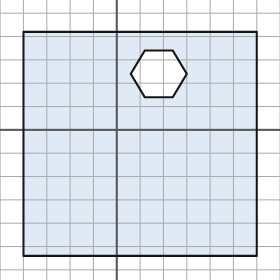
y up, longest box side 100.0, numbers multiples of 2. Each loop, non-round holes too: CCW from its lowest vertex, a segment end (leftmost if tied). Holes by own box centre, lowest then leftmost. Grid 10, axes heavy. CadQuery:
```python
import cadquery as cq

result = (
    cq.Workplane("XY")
    .moveTo(-40.0, -54.0)
    .lineTo(60.0, -54.0)
    .lineTo(60.0, 42.0)
    .lineTo(-40.0, 42.0)
    .close()
    .moveTo(12.0, 14.0)
    .lineTo(24.0, 14.0)
    .lineTo(30.0, 24.0)
    .lineTo(24.0, 34.0)
    .lineTo(12.0, 34.0)
    .lineTo(6.0, 24.0)
    .close()
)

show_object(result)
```